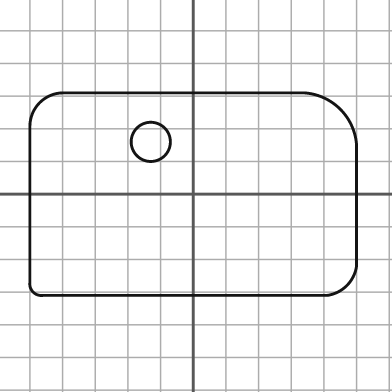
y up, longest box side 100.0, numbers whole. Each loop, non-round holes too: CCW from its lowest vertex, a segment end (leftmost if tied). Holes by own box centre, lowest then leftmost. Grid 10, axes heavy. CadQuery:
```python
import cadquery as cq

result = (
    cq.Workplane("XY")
    .moveTo(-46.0, -31.0)
    .lineTo(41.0, -31.0)
    .threePointArc((47.0, -28.0), (50.0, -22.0))
    .lineTo(50.0, 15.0)
    .threePointArc((45.0, 26.0), (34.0, 31.0))
    .lineTo(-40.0, 31.0)
    .threePointArc((-47.0, 28.0), (-50.0, 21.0))
    .lineTo(-50.0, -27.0)
    .threePointArc((-49.0, -30.0), (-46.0, -31.0))
    .close()
    .moveTo(-13.0, 16.0)
    .circle(6.0)
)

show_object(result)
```